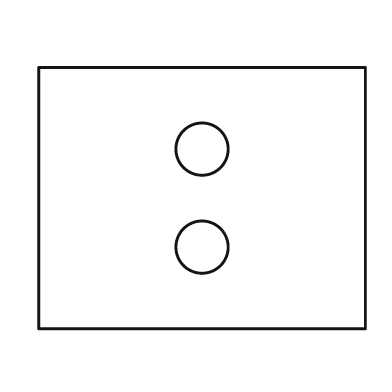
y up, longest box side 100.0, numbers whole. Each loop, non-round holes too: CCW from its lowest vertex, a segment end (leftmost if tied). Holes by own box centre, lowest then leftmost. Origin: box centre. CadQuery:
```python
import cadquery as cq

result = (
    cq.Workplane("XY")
    .moveTo(-50.0, -40.0)
    .lineTo(50.0, -40.0)
    .lineTo(50.0, 40.0)
    .lineTo(-50.0, 40.0)
    .close()
    .moveTo(0.0, -15.0)
    .circle(8.0)
    .moveTo(0.0, 15.0)
    .circle(8.0)
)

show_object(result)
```